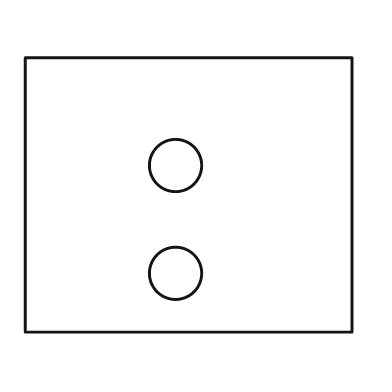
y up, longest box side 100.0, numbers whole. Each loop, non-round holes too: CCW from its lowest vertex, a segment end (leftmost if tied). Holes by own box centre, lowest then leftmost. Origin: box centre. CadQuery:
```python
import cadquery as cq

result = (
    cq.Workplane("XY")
    .moveTo(-50.0, -42.0)
    .lineTo(50.0, -42.0)
    .lineTo(50.0, 42.0)
    .lineTo(-50.0, 42.0)
    .close()
    .moveTo(-4.0, -24.0)
    .circle(8.0)
    .moveTo(-4.0, 9.0)
    .circle(8.0)
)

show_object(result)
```